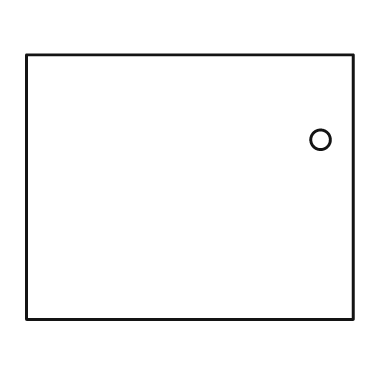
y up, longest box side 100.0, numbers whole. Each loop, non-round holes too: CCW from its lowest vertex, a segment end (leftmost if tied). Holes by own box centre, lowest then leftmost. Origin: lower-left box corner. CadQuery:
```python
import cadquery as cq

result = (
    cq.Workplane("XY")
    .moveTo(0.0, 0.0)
    .lineTo(100.0, 0.0)
    .lineTo(100.0, 81.0)
    .lineTo(0.0, 81.0)
    .close()
    .moveTo(90.0, 55.0)
    .circle(3.0)
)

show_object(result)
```